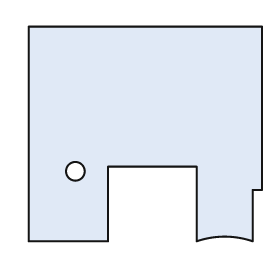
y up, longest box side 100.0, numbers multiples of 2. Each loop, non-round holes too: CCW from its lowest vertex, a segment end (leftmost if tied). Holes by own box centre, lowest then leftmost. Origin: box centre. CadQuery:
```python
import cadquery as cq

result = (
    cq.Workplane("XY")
    .moveTo(-50.0, -46.0)
    .lineTo(-16.0, -46.0)
    .lineTo(-16.0, -14.0)
    .lineTo(22.0, -14.0)
    .lineTo(22.0, -46.0)
    .threePointArc((34.0, -44.0), (46.0, -46.0))
    .lineTo(46.0, -24.0)
    .lineTo(50.0, -24.0)
    .lineTo(50.0, 46.0)
    .lineTo(-50.0, 46.0)
    .close()
    .moveTo(-30.0, -16.0)
    .circle(4.0)
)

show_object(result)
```